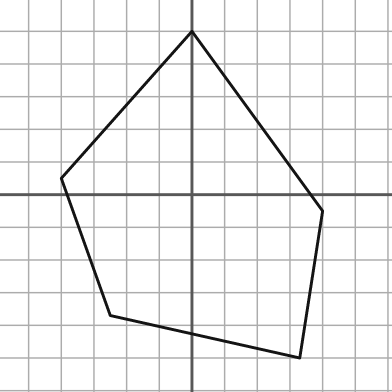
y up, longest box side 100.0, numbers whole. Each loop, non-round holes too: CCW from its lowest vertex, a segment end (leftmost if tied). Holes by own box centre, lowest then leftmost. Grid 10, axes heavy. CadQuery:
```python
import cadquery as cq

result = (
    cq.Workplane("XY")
    .moveTo(33.0, -50.0)
    .lineTo(40.0, -5.0)
    .lineTo(0.0, 50.0)
    .lineTo(-40.0, 5.0)
    .lineTo(-25.0, -37.0)
    .close()
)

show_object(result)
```